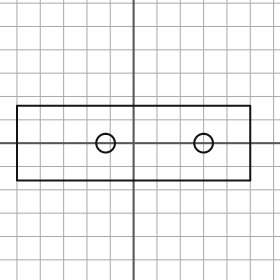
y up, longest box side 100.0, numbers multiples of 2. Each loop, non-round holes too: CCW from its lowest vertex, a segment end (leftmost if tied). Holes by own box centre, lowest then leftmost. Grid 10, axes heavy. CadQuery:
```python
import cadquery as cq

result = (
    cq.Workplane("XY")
    .moveTo(-50.0, -16.0)
    .lineTo(50.0, -16.0)
    .lineTo(50.0, 16.0)
    .lineTo(-50.0, 16.0)
    .close()
    .moveTo(-12.0, 0.0)
    .circle(4.0)
    .moveTo(30.0, 0.0)
    .circle(4.0)
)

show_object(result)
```